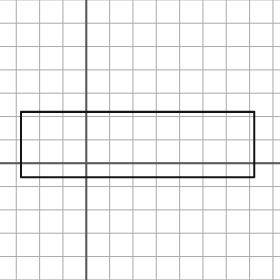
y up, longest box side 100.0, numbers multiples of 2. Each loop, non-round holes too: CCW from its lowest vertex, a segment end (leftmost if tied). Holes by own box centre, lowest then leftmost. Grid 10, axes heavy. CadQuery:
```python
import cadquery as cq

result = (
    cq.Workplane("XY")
    .moveTo(-28.0, -6.0)
    .lineTo(72.0, -6.0)
    .lineTo(72.0, 22.0)
    .lineTo(-28.0, 22.0)
    .close()
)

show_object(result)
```